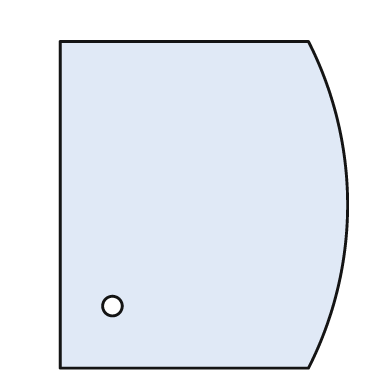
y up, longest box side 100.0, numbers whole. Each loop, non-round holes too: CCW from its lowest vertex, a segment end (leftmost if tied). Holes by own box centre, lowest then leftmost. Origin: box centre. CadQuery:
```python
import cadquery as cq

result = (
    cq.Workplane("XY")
    .moveTo(-44.0, -50.0)
    .lineTo(32.0, -50.0)
    .threePointArc((44.0, 0.0), (32.0, 50.0))
    .lineTo(-44.0, 50.0)
    .close()
    .moveTo(-28.0, -31.0)
    .circle(3.0)
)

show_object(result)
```